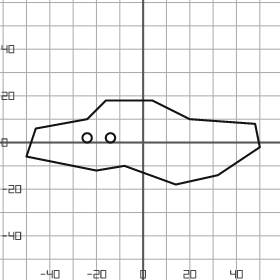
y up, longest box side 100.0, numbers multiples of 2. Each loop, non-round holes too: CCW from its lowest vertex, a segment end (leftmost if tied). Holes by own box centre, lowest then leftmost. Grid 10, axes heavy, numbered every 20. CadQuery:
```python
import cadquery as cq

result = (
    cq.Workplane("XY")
    .moveTo(14.0, -18.0)
    .lineTo(32.0, -14.0)
    .lineTo(50.0, -2.0)
    .lineTo(48.0, 8.0)
    .lineTo(20.0, 10.0)
    .lineTo(4.0, 18.0)
    .lineTo(-16.0, 18.0)
    .lineTo(-24.0, 10.0)
    .lineTo(-46.0, 6.0)
    .lineTo(-50.0, -6.0)
    .lineTo(-20.0, -12.0)
    .lineTo(-8.0, -10.0)
    .close()
    .moveTo(-24.0, 2.0)
    .circle(2.0)
    .moveTo(-14.0, 2.0)
    .circle(2.0)
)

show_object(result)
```